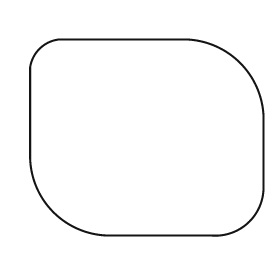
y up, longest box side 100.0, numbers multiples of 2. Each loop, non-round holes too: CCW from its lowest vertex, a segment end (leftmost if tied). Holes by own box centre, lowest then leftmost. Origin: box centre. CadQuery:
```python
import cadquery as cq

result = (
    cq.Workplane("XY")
    .moveTo(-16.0, -42.0)
    .lineTo(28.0, -42.0)
    .threePointArc((44.0, -36.0), (50.0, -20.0))
    .lineTo(50.0, 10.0)
    .threePointArc((40.0, 32.0), (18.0, 42.0))
    .lineTo(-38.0, 42.0)
    .threePointArc((-46.0, 38.0), (-50.0, 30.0))
    .lineTo(-50.0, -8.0)
    .threePointArc((-40.0, -32.0), (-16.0, -42.0))
    .close()
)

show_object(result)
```